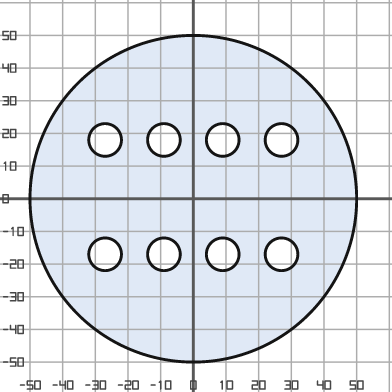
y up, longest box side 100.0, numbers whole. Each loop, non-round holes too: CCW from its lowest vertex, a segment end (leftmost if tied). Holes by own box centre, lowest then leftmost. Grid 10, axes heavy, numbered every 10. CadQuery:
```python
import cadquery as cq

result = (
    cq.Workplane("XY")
    .moveTo(0.0, 0.0)
    .circle(50.0)
    .moveTo(-27.0, -17.0)
    .circle(5.0)
    .moveTo(-9.0, -17.0)
    .circle(5.0)
    .moveTo(9.0, -17.0)
    .circle(5.0)
    .moveTo(27.0, -17.0)
    .circle(5.0)
    .moveTo(-27.0, 18.0)
    .circle(5.0)
    .moveTo(-9.0, 18.0)
    .circle(5.0)
    .moveTo(9.0, 18.0)
    .circle(5.0)
    .moveTo(27.0, 18.0)
    .circle(5.0)
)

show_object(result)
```